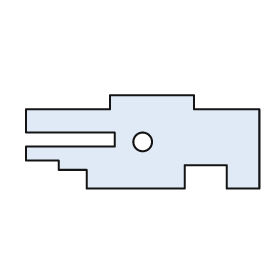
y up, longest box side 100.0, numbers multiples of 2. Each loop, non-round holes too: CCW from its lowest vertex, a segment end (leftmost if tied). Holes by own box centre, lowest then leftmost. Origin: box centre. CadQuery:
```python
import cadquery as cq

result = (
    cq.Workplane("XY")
    .moveTo(-24.0, -20.0)
    .lineTo(18.0, -20.0)
    .lineTo(18.0, -10.0)
    .lineTo(36.0, -10.0)
    .lineTo(36.0, -20.0)
    .lineTo(50.0, -20.0)
    .lineTo(50.0, 14.0)
    .lineTo(22.0, 14.0)
    .lineTo(22.0, 20.0)
    .lineTo(-14.0, 20.0)
    .lineTo(-14.0, 14.0)
    .lineTo(-50.0, 14.0)
    .lineTo(-50.0, 4.0)
    .lineTo(-12.0, 4.0)
    .lineTo(-12.0, -2.0)
    .lineTo(-50.0, -2.0)
    .lineTo(-50.0, -8.0)
    .lineTo(-36.0, -8.0)
    .lineTo(-36.0, -12.0)
    .lineTo(-24.0, -12.0)
    .close()
    .moveTo(0.0, 0.0)
    .circle(4.0)
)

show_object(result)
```